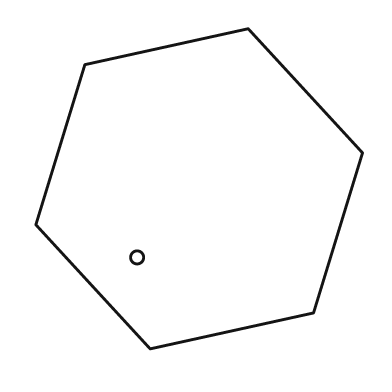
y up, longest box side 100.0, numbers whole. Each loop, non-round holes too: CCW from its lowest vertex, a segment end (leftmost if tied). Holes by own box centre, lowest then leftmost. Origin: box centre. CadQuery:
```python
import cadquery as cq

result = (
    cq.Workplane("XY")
    .moveTo(-15.0, -49.0)
    .lineTo(35.0, -38.0)
    .lineTo(50.0, 11.0)
    .lineTo(15.0, 49.0)
    .lineTo(-35.0, 38.0)
    .lineTo(-50.0, -11.0)
    .close()
    .moveTo(-19.0, -21.0)
    .circle(2.0)
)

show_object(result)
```